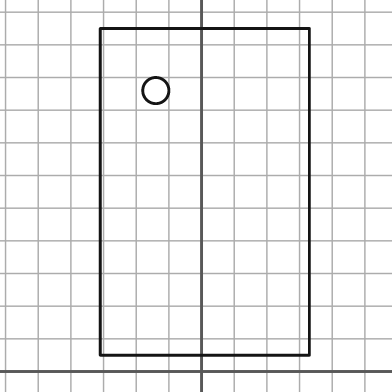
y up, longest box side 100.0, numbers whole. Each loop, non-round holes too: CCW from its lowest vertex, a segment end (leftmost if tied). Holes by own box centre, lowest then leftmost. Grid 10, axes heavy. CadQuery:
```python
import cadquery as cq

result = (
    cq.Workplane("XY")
    .moveTo(-31.0, 5.0)
    .lineTo(33.0, 5.0)
    .lineTo(33.0, 105.0)
    .lineTo(-31.0, 105.0)
    .close()
    .moveTo(-14.0, 86.0)
    .circle(4.0)
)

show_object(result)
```